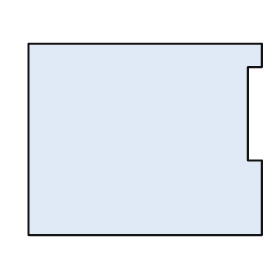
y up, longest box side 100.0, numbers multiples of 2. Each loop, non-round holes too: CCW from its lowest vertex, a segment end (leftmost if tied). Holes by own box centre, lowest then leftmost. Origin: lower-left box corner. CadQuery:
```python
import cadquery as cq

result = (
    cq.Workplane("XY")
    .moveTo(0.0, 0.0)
    .lineTo(100.0, 0.0)
    .lineTo(100.0, 32.0)
    .lineTo(94.0, 32.0)
    .lineTo(94.0, 72.0)
    .lineTo(100.0, 72.0)
    .lineTo(100.0, 82.0)
    .lineTo(0.0, 82.0)
    .close()
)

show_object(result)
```